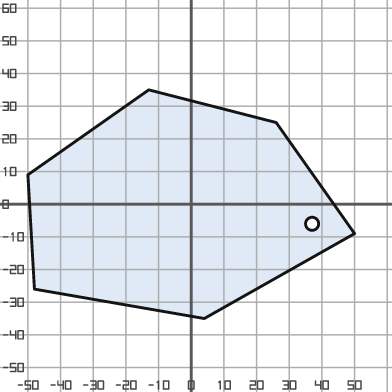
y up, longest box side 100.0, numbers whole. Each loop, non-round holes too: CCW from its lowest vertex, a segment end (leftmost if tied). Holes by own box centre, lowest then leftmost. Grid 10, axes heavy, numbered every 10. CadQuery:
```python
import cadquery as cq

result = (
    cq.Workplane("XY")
    .moveTo(4.0, -35.0)
    .lineTo(50.0, -9.0)
    .lineTo(26.0, 25.0)
    .lineTo(-13.0, 35.0)
    .lineTo(-50.0, 9.0)
    .lineTo(-48.0, -26.0)
    .close()
    .moveTo(37.0, -6.0)
    .circle(2.0)
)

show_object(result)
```